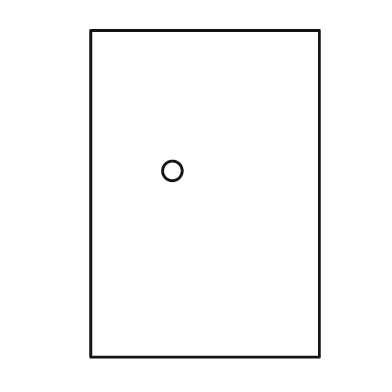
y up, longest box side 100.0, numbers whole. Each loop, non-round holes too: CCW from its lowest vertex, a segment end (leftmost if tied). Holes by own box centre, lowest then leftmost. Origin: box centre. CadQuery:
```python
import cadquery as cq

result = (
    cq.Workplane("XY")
    .moveTo(-35.0, -50.0)
    .lineTo(35.0, -50.0)
    .lineTo(35.0, 50.0)
    .lineTo(-35.0, 50.0)
    .close()
    .moveTo(-10.0, 7.0)
    .circle(3.0)
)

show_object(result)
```